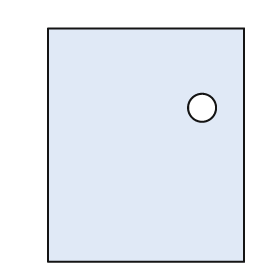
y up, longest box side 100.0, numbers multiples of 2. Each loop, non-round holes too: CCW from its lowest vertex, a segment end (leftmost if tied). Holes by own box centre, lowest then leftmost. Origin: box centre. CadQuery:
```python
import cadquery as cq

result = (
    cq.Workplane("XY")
    .moveTo(-42.0, -50.0)
    .lineTo(42.0, -50.0)
    .lineTo(42.0, 50.0)
    .lineTo(-42.0, 50.0)
    .close()
    .moveTo(24.0, 16.0)
    .circle(6.0)
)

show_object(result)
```